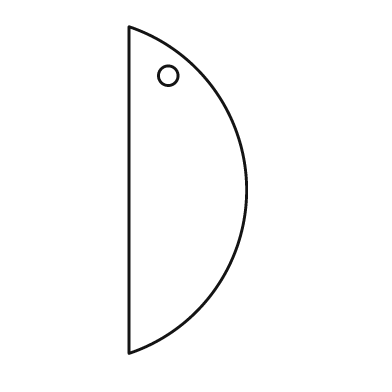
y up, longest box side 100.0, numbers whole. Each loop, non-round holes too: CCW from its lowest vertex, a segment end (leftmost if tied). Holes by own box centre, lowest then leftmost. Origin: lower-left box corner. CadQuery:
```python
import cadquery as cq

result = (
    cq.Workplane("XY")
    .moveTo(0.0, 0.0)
    .threePointArc((36.0, 50.0), (0.0, 100.0))
    .close()
    .moveTo(12.0, 85.0)
    .circle(3.0)
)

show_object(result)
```